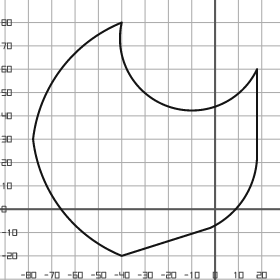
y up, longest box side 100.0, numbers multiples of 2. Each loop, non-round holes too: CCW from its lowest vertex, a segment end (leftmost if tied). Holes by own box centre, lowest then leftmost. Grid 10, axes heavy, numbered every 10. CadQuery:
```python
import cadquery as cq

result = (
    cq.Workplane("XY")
    .moveTo(-40.0, -20.0)
    .lineTo(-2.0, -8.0)
    .threePointArc((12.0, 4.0), (18.0, 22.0))
    .lineTo(18.0, 60.0)
    .threePointArc((-20.0, 44.0), (-40.0, 80.0))
    .threePointArc((-66.0, 60.0), (-78.0, 30.0))
    .threePointArc((-66.0, 0.0), (-40.0, -20.0))
    .close()
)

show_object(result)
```